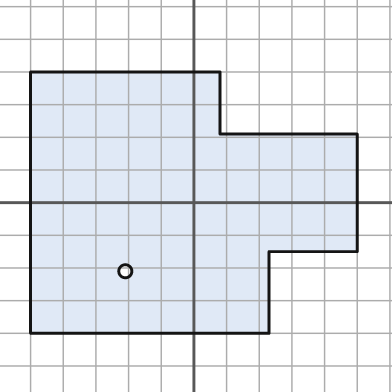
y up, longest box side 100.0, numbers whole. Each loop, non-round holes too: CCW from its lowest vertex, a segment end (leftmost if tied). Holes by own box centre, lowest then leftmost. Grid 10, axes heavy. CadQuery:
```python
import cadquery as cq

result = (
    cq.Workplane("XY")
    .moveTo(-50.0, -40.0)
    .lineTo(23.0, -40.0)
    .lineTo(23.0, -15.0)
    .lineTo(50.0, -15.0)
    .lineTo(50.0, 21.0)
    .lineTo(8.0, 21.0)
    .lineTo(8.0, 40.0)
    .lineTo(-50.0, 40.0)
    .close()
    .moveTo(-21.0, -21.0)
    .circle(2.0)
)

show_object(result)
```